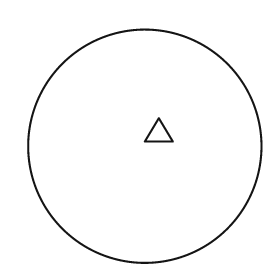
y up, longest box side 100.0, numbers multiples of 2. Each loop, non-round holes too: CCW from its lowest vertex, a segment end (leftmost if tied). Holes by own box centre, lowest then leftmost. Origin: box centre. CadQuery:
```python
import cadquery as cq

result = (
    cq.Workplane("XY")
    .moveTo(0.0, 0.0)
    .circle(50.0)
    .moveTo(0.0, 2.0)
    .lineTo(12.0, 2.0)
    .lineTo(6.0, 12.0)
    .close()
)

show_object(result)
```